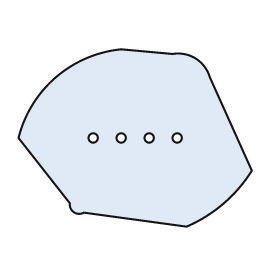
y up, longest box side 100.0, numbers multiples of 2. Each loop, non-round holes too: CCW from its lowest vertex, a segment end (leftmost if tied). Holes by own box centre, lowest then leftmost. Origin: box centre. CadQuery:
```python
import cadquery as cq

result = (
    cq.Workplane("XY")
    .moveTo(22.0, -38.0)
    .threePointArc((38.0, -28.0), (50.0, -14.0))
    .lineTo(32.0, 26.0)
    .threePointArc((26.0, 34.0), (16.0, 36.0))
    .lineTo(-6.0, 38.0)
    .threePointArc((-34.0, 26.0), (-50.0, 0.0))
    .lineTo(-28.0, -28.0)
    .threePointArc((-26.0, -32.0), (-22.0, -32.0))
    .close()
    .moveTo(-18.0, 0.0)
    .circle(2.0)
    .moveTo(-6.0, 0.0)
    .circle(2.0)
    .moveTo(6.0, 0.0)
    .circle(2.0)
    .moveTo(18.0, 0.0)
    .circle(2.0)
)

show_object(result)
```